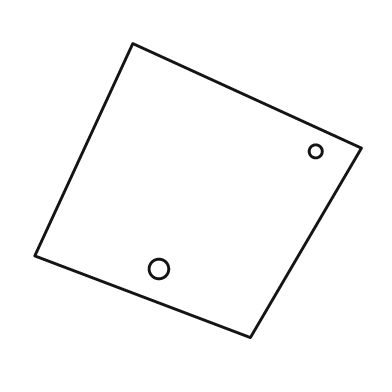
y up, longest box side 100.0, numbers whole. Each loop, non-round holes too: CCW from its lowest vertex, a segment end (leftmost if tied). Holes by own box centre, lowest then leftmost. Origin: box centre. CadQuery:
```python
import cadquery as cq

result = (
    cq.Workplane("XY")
    .moveTo(16.0, -45.0)
    .lineTo(50.0, 13.0)
    .lineTo(-20.0, 45.0)
    .lineTo(-50.0, -20.0)
    .close()
    .moveTo(-12.0, -24.0)
    .circle(3.0)
    .moveTo(36.0, 12.0)
    .circle(2.0)
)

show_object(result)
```